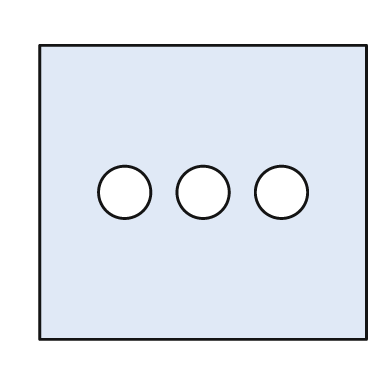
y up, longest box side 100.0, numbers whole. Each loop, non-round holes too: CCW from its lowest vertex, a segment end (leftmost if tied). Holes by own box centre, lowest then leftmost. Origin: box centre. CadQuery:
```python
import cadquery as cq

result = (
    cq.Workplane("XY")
    .moveTo(-50.0, -45.0)
    .lineTo(50.0, -45.0)
    .lineTo(50.0, 45.0)
    .lineTo(-50.0, 45.0)
    .close()
    .moveTo(-24.0, 0.0)
    .circle(8.0)
    .moveTo(0.0, 0.0)
    .circle(8.0)
    .moveTo(24.0, 0.0)
    .circle(8.0)
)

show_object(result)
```